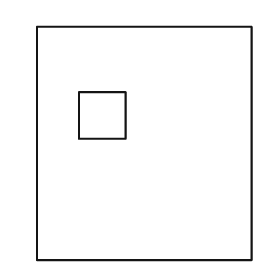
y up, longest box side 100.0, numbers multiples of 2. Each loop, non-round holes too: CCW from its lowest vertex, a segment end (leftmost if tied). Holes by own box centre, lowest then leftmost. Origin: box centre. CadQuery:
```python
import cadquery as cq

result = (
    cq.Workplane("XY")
    .moveTo(-46.0, -50.0)
    .lineTo(46.0, -50.0)
    .lineTo(46.0, 50.0)
    .lineTo(-46.0, 50.0)
    .close()
    .moveTo(-28.0, 2.0)
    .lineTo(-8.0, 2.0)
    .lineTo(-8.0, 22.0)
    .lineTo(-28.0, 22.0)
    .close()
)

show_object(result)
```